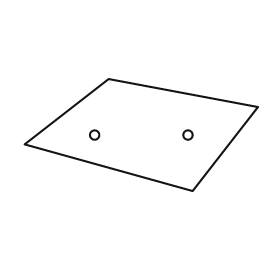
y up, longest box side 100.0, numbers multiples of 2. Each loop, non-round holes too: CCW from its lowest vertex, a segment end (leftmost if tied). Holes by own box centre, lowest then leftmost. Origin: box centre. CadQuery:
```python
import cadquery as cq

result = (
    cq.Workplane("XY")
    .moveTo(22.0, -24.0)
    .lineTo(50.0, 12.0)
    .lineTo(-14.0, 24.0)
    .lineTo(-50.0, -4.0)
    .close()
    .moveTo(-20.0, 0.0)
    .circle(2.0)
    .moveTo(20.0, 0.0)
    .circle(2.0)
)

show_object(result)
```